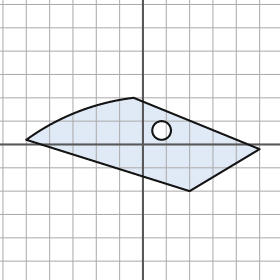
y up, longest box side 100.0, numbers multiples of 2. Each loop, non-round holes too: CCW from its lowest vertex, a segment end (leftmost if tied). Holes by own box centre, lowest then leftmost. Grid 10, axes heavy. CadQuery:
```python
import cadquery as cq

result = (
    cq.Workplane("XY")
    .moveTo(20.0, -20.0)
    .lineTo(50.0, -2.0)
    .lineTo(-4.0, 20.0)
    .threePointArc((-28.0, 14.0), (-50.0, 2.0))
    .close()
    .moveTo(8.0, 6.0)
    .circle(4.0)
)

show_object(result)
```